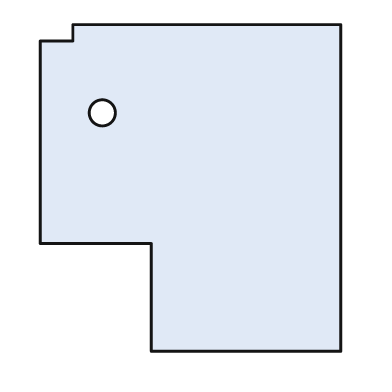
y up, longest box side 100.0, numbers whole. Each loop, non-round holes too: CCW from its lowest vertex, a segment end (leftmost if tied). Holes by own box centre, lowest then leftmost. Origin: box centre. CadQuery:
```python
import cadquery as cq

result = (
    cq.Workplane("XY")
    .moveTo(-12.0, -50.0)
    .lineTo(46.0, -50.0)
    .lineTo(46.0, 50.0)
    .lineTo(-36.0, 50.0)
    .lineTo(-36.0, 45.0)
    .lineTo(-46.0, 45.0)
    .lineTo(-46.0, -17.0)
    .lineTo(-12.0, -17.0)
    .close()
    .moveTo(-27.0, 23.0)
    .circle(4.0)
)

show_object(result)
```